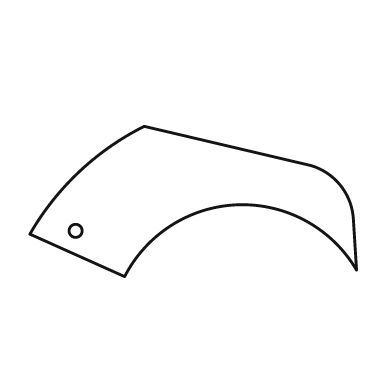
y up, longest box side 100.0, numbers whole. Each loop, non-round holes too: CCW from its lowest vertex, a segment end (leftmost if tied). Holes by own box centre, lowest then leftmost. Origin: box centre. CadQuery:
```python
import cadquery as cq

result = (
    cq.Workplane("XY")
    .moveTo(-21.0, -23.0)
    .threePointArc((14.0, -1.0), (50.0, -21.0))
    .lineTo(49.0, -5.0)
    .threePointArc((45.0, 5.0), (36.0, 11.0))
    .lineTo(-15.0, 23.0)
    .threePointArc((-35.0, 9.0), (-50.0, -10.0))
    .close()
    .moveTo(-36.0, -9.0)
    .circle(2.0)
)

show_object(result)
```